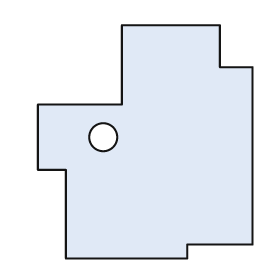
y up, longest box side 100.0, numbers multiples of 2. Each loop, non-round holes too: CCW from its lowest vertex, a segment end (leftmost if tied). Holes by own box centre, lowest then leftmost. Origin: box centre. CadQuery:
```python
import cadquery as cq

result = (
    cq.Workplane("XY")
    .moveTo(-34.0, -50.0)
    .lineTo(18.0, -50.0)
    .lineTo(18.0, -44.0)
    .lineTo(46.0, -44.0)
    .lineTo(46.0, 32.0)
    .lineTo(32.0, 32.0)
    .lineTo(32.0, 50.0)
    .lineTo(-10.0, 50.0)
    .lineTo(-10.0, 16.0)
    .lineTo(-46.0, 16.0)
    .lineTo(-46.0, -12.0)
    .lineTo(-34.0, -12.0)
    .close()
    .moveTo(-18.0, 2.0)
    .circle(6.0)
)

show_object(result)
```